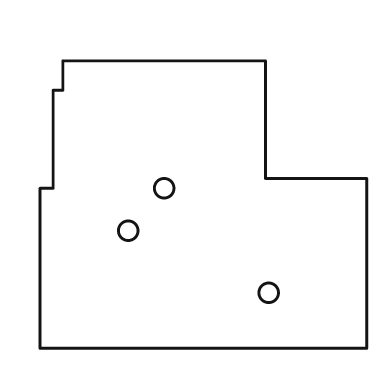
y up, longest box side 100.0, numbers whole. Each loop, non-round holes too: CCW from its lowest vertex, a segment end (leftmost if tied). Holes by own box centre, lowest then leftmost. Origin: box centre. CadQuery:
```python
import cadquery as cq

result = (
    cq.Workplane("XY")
    .moveTo(-50.0, -44.0)
    .lineTo(50.0, -44.0)
    .lineTo(50.0, 8.0)
    .lineTo(19.0, 8.0)
    .lineTo(19.0, 44.0)
    .lineTo(-43.0, 44.0)
    .lineTo(-43.0, 35.0)
    .lineTo(-46.0, 35.0)
    .lineTo(-46.0, 5.0)
    .lineTo(-50.0, 5.0)
    .close()
    .moveTo(20.0, -27.0)
    .circle(3.0)
    .moveTo(-23.0, -8.0)
    .circle(3.0)
    .moveTo(-12.0, 5.0)
    .circle(3.0)
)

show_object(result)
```